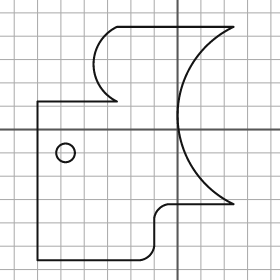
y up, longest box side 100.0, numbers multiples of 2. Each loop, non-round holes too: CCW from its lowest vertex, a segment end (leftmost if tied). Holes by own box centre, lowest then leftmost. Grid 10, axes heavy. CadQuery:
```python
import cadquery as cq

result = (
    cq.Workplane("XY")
    .moveTo(-60.0, -56.0)
    .lineTo(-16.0, -56.0)
    .threePointArc((-12.0, -54.0), (-10.0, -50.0))
    .lineTo(-10.0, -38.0)
    .threePointArc((-8.0, -34.0), (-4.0, -32.0))
    .lineTo(24.0, -32.0)
    .threePointArc((0.0, 6.0), (24.0, 44.0))
    .lineTo(-26.0, 44.0)
    .threePointArc((-36.0, 28.0), (-26.0, 12.0))
    .lineTo(-60.0, 12.0)
    .close()
    .moveTo(-48.0, -10.0)
    .circle(4.0)
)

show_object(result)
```